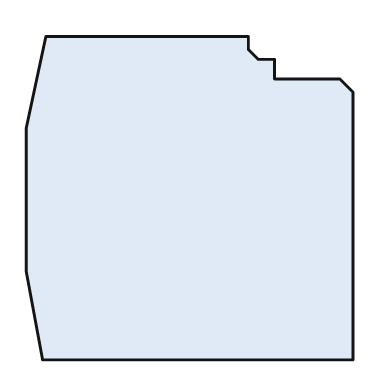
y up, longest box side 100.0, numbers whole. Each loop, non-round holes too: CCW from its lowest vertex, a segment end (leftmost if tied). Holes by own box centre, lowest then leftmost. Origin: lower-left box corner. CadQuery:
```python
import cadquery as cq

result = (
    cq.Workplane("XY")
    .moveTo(5.0, 0.0)
    .lineTo(100.0, 0.0)
    .lineTo(100.0, 82.0)
    .lineTo(96.0, 86.0)
    .lineTo(76.0, 86.0)
    .lineTo(76.0, 92.0)
    .lineTo(71.0, 92.0)
    .lineTo(68.0, 95.0)
    .lineTo(68.0, 99.0)
    .lineTo(6.0, 99.0)
    .lineTo(0.0, 71.0)
    .lineTo(0.0, 27.0)
    .close()
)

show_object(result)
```